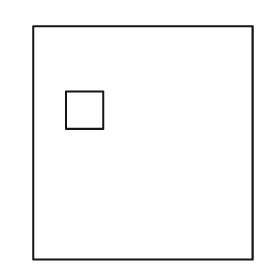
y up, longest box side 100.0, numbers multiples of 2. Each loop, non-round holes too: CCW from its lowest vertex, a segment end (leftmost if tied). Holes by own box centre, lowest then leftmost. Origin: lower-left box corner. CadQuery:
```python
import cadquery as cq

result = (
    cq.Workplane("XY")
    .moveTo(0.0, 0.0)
    .lineTo(94.0, 0.0)
    .lineTo(94.0, 100.0)
    .lineTo(0.0, 100.0)
    .close()
    .moveTo(14.0, 56.0)
    .lineTo(30.0, 56.0)
    .lineTo(30.0, 72.0)
    .lineTo(14.0, 72.0)
    .close()
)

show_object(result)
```